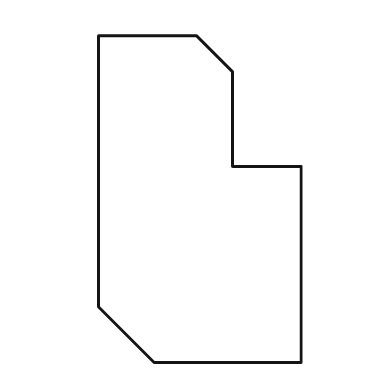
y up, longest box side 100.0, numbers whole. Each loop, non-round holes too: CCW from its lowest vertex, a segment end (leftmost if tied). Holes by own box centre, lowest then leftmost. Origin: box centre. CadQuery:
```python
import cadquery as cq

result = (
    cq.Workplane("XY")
    .moveTo(-14.0, -50.0)
    .lineTo(31.0, -50.0)
    .lineTo(31.0, 10.0)
    .lineTo(10.0, 10.0)
    .lineTo(10.0, 39.0)
    .lineTo(-1.0, 50.0)
    .lineTo(-31.0, 50.0)
    .lineTo(-31.0, -33.0)
    .close()
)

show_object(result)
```